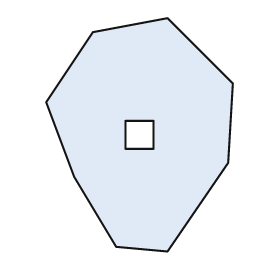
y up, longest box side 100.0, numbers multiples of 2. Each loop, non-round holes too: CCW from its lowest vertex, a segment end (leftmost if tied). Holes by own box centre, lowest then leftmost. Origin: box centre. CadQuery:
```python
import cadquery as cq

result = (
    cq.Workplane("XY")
    .moveTo(12.0, -50.0)
    .lineTo(38.0, -12.0)
    .lineTo(40.0, 22.0)
    .lineTo(12.0, 50.0)
    .lineTo(-20.0, 44.0)
    .lineTo(-40.0, 14.0)
    .lineTo(-28.0, -18.0)
    .lineTo(-10.0, -48.0)
    .close()
    .moveTo(-6.0, -6.0)
    .lineTo(6.0, -6.0)
    .lineTo(6.0, 6.0)
    .lineTo(-6.0, 6.0)
    .close()
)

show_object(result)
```